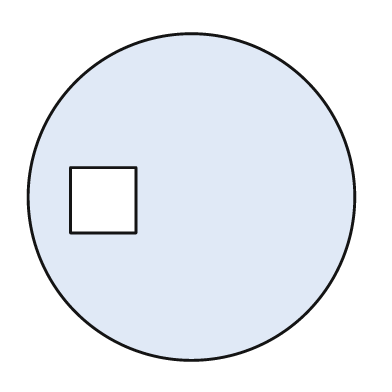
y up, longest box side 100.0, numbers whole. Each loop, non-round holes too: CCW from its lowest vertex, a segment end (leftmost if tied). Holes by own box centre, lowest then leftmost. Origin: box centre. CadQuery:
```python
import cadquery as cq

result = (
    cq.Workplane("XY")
    .moveTo(0.0, 0.0)
    .circle(50.0)
    .moveTo(-37.0, -11.0)
    .lineTo(-17.0, -11.0)
    .lineTo(-17.0, 9.0)
    .lineTo(-37.0, 9.0)
    .close()
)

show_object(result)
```